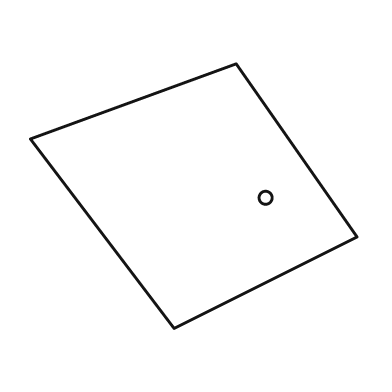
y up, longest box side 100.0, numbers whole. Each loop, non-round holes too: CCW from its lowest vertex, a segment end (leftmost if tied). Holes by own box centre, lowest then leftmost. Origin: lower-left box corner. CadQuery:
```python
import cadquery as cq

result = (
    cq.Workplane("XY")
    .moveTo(44.0, 0.0)
    .lineTo(100.0, 28.0)
    .lineTo(63.0, 81.0)
    .lineTo(0.0, 58.0)
    .close()
    .moveTo(72.0, 40.0)
    .circle(2.0)
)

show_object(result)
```